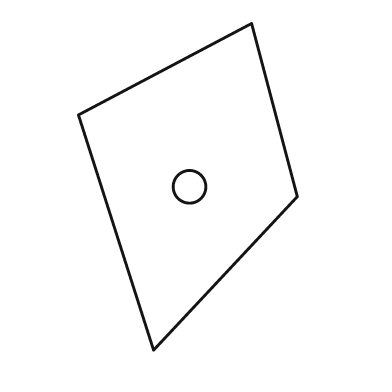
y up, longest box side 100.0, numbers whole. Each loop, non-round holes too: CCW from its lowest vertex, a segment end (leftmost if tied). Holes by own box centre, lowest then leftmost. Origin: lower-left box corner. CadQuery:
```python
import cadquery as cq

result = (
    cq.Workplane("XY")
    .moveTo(23.0, 0.0)
    .lineTo(67.0, 47.0)
    .lineTo(53.0, 100.0)
    .lineTo(0.0, 72.0)
    .close()
    .moveTo(34.0, 50.0)
    .circle(5.0)
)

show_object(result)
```